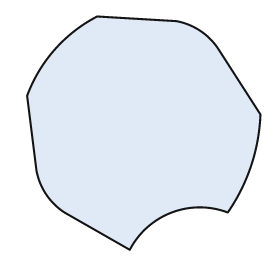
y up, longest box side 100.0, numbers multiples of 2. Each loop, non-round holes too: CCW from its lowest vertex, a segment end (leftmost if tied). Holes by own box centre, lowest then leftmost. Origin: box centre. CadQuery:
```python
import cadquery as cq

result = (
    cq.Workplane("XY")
    .moveTo(-6.0, -50.0)
    .threePointArc((12.0, -34.0), (36.0, -34.0))
    .threePointArc((46.0, -14.0), (50.0, 8.0))
    .lineTo(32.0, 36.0)
    .threePointArc((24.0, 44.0), (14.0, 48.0))
    .lineTo(-20.0, 50.0)
    .threePointArc((-38.0, 36.0), (-50.0, 16.0))
    .lineTo(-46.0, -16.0)
    .threePointArc((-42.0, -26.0), (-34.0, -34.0))
    .close()
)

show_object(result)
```